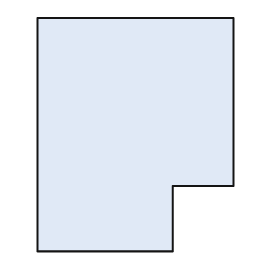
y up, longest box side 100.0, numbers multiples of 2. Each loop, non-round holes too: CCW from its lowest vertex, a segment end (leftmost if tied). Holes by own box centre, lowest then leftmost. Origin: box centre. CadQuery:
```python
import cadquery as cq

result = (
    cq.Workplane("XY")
    .moveTo(-42.0, -50.0)
    .lineTo(16.0, -50.0)
    .lineTo(16.0, -22.0)
    .lineTo(42.0, -22.0)
    .lineTo(42.0, 50.0)
    .lineTo(-42.0, 50.0)
    .close()
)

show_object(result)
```